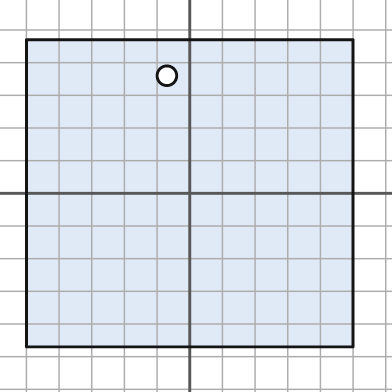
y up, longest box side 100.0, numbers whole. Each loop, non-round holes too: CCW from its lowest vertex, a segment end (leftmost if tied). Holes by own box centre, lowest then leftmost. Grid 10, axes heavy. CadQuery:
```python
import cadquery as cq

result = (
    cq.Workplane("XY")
    .moveTo(-50.0, -47.0)
    .lineTo(50.0, -47.0)
    .lineTo(50.0, 47.0)
    .lineTo(-50.0, 47.0)
    .close()
    .moveTo(-7.0, 36.0)
    .circle(3.0)
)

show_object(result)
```